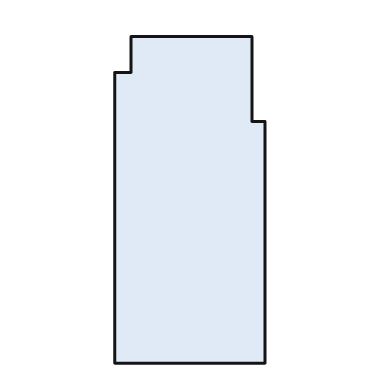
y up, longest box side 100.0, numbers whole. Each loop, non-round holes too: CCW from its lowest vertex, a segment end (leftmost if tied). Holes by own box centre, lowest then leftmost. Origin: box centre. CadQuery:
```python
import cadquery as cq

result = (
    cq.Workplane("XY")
    .moveTo(-23.0, -50.0)
    .lineTo(23.0, -50.0)
    .lineTo(23.0, 24.0)
    .lineTo(19.0, 24.0)
    .lineTo(19.0, 50.0)
    .lineTo(-18.0, 50.0)
    .lineTo(-18.0, 39.0)
    .lineTo(-23.0, 39.0)
    .close()
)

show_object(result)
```